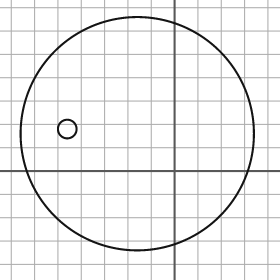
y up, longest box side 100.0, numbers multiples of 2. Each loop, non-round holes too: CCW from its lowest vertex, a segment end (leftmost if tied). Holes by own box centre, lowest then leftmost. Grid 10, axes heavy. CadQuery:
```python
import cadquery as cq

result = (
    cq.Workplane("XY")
    .moveTo(-16.0, 16.0)
    .circle(50.0)
    .moveTo(-46.0, 18.0)
    .circle(4.0)
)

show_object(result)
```